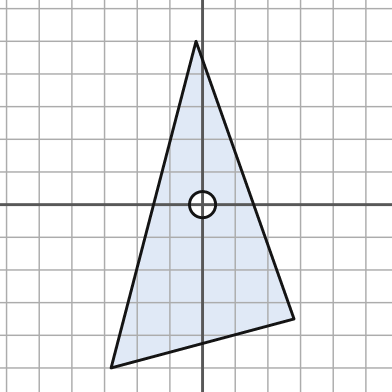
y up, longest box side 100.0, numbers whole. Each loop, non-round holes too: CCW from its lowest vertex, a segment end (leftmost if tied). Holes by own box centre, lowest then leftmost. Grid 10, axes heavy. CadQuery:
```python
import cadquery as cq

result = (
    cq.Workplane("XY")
    .moveTo(-28.0, -50.0)
    .lineTo(28.0, -35.0)
    .lineTo(-2.0, 50.0)
    .close()
    .moveTo(0.0, 0.0)
    .circle(4.0)
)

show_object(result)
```